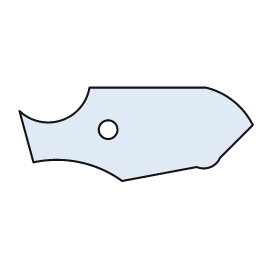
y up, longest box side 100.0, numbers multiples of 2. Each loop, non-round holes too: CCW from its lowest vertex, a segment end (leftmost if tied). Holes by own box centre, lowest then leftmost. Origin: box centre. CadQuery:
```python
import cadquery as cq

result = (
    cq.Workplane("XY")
    .moveTo(-6.0, -20.0)
    .lineTo(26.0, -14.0)
    .threePointArc((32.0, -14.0), (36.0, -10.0))
    .lineTo(50.0, 4.0)
    .threePointArc((42.0, 14.0), (30.0, 20.0))
    .lineTo(-20.0, 20.0)
    .threePointArc((-32.0, 6.0), (-50.0, 10.0))
    .lineTo(-44.0, -12.0)
    .threePointArc((-24.0, -12.0), (-6.0, -20.0))
    .close()
    .moveTo(-12.0, 2.0)
    .circle(4.0)
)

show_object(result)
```